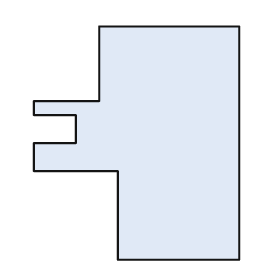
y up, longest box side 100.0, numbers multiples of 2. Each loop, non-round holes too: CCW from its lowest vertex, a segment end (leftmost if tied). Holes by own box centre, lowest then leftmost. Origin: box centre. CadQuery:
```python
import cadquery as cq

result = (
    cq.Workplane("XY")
    .moveTo(-8.0, -50.0)
    .lineTo(44.0, -50.0)
    .lineTo(44.0, 50.0)
    .lineTo(-16.0, 50.0)
    .lineTo(-16.0, 18.0)
    .lineTo(-44.0, 18.0)
    .lineTo(-44.0, 12.0)
    .lineTo(-26.0, 12.0)
    .lineTo(-26.0, 0.0)
    .lineTo(-44.0, 0.0)
    .lineTo(-44.0, -12.0)
    .lineTo(-8.0, -12.0)
    .close()
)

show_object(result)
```